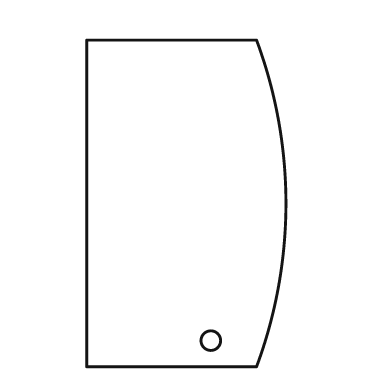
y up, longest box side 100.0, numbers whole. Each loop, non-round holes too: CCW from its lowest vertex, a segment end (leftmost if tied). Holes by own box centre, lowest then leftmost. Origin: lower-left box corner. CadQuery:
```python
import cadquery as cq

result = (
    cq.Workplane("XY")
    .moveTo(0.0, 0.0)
    .lineTo(52.0, 0.0)
    .threePointArc((61.0, 50.0), (52.0, 100.0))
    .lineTo(0.0, 100.0)
    .close()
    .moveTo(38.0, 8.0)
    .circle(3.0)
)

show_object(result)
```